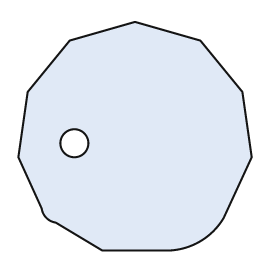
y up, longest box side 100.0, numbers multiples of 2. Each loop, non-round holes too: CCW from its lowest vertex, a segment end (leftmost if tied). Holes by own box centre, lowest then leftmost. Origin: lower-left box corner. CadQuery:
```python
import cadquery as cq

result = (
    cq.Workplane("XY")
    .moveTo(36.0, 0.0)
    .lineTo(64.0, 0.0)
    .threePointArc((78.0, 4.0), (88.0, 14.0))
    .lineTo(100.0, 40.0)
    .lineTo(96.0, 68.0)
    .lineTo(78.0, 90.0)
    .lineTo(50.0, 98.0)
    .lineTo(22.0, 90.0)
    .lineTo(4.0, 68.0)
    .lineTo(0.0, 40.0)
    .lineTo(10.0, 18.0)
    .threePointArc((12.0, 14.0), (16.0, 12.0))
    .close()
    .moveTo(24.0, 46.0)
    .circle(6.0)
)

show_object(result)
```